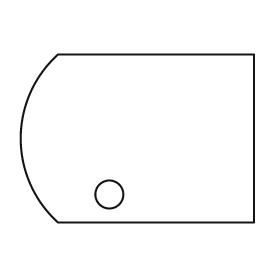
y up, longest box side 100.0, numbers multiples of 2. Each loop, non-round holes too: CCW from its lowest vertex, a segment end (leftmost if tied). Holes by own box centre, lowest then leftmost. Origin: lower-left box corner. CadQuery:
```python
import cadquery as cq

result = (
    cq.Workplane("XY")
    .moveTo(16.0, 0.0)
    .lineTo(100.0, 0.0)
    .lineTo(100.0, 72.0)
    .lineTo(16.0, 72.0)
    .threePointArc((0.0, 36.0), (16.0, 0.0))
    .close()
    .moveTo(38.0, 12.0)
    .circle(6.0)
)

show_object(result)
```